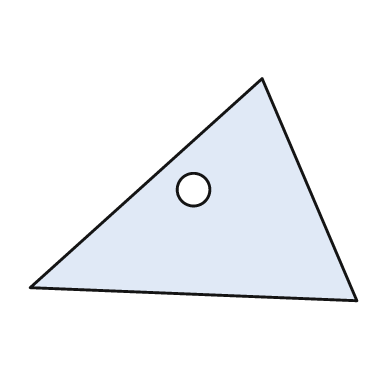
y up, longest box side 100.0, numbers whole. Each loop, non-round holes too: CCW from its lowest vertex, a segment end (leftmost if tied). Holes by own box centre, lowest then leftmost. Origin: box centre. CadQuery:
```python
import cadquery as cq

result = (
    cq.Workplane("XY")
    .moveTo(50.0, -34.0)
    .lineTo(21.0, 34.0)
    .lineTo(-50.0, -30.0)
    .close()
    .moveTo(0.0, 0.0)
    .circle(5.0)
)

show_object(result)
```